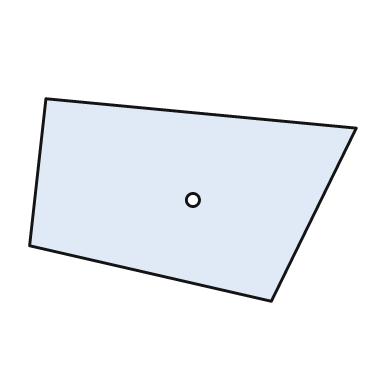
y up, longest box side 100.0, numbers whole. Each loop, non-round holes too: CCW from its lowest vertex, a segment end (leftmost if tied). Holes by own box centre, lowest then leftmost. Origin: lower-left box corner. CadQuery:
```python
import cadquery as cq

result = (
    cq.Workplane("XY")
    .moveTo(74.0, 0.0)
    .lineTo(100.0, 53.0)
    .lineTo(5.0, 62.0)
    .lineTo(0.0, 17.0)
    .close()
    .moveTo(50.0, 31.0)
    .circle(2.0)
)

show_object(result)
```